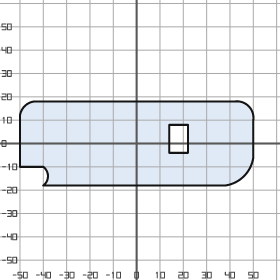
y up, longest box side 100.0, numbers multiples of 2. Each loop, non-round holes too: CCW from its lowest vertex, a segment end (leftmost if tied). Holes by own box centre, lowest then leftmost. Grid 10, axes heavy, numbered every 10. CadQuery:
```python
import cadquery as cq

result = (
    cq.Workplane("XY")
    .moveTo(-40.0, -18.0)
    .lineTo(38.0, -18.0)
    .threePointArc((46.0, -14.0), (50.0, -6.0))
    .lineTo(50.0, 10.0)
    .threePointArc((48.0, 16.0), (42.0, 18.0))
    .lineTo(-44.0, 18.0)
    .threePointArc((-48.0, 16.0), (-50.0, 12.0))
    .lineTo(-50.0, -10.0)
    .lineTo(-40.0, -10.0)
    .threePointArc((-38.0, -14.0), (-40.0, -18.0))
    .close()
    .moveTo(14.0, -4.0)
    .lineTo(22.0, -4.0)
    .lineTo(22.0, 8.0)
    .lineTo(14.0, 8.0)
    .close()
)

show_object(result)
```